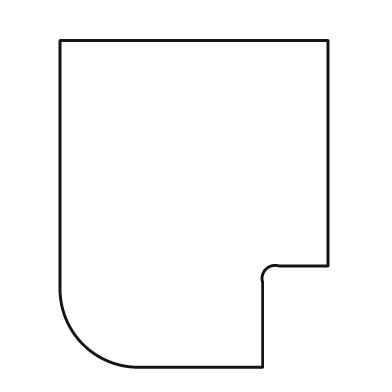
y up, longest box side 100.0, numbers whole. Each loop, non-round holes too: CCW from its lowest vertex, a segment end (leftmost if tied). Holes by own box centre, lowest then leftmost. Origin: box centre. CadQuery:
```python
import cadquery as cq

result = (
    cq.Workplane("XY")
    .moveTo(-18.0, -50.0)
    .lineTo(21.0, -50.0)
    .lineTo(21.0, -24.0)
    .threePointArc((22.0, -20.0), (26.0, -19.0))
    .lineTo(41.0, -19.0)
    .lineTo(41.0, 50.0)
    .lineTo(-41.0, 50.0)
    .lineTo(-41.0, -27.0)
    .threePointArc((-34.0, -43.0), (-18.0, -50.0))
    .close()
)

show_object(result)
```